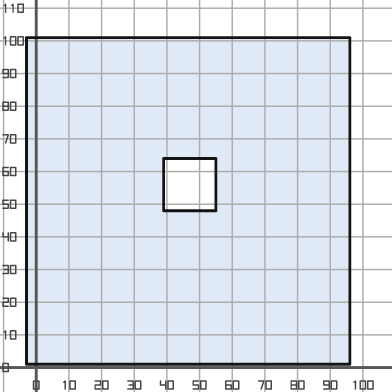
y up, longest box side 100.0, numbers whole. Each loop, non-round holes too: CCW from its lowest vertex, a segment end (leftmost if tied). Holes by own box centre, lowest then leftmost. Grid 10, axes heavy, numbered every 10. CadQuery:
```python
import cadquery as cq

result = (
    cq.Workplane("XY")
    .moveTo(-3.0, 1.0)
    .lineTo(96.0, 1.0)
    .lineTo(96.0, 101.0)
    .lineTo(-3.0, 101.0)
    .close()
    .moveTo(39.0, 48.0)
    .lineTo(55.0, 48.0)
    .lineTo(55.0, 64.0)
    .lineTo(39.0, 64.0)
    .close()
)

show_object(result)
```